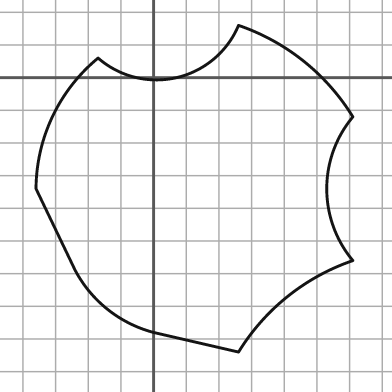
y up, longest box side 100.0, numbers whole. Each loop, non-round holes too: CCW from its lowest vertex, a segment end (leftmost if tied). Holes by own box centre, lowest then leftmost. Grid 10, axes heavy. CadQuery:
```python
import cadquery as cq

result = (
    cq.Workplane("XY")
    .moveTo(26.0, -84.0)
    .threePointArc((41.0, -67.0), (61.0, -56.0))
    .threePointArc((53.0, -34.0), (61.0, -12.0))
    .threePointArc((46.0, 5.0), (26.0, 16.0))
    .threePointArc((7.0, 0.0), (-17.0, 6.0))
    .threePointArc((-31.0, -12.0), (-36.0, -34.0))
    .lineTo(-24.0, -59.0)
    .threePointArc((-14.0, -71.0), (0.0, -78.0))
    .close()
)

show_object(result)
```